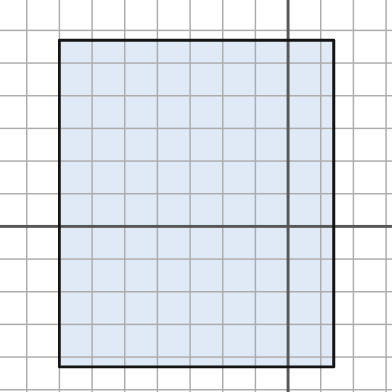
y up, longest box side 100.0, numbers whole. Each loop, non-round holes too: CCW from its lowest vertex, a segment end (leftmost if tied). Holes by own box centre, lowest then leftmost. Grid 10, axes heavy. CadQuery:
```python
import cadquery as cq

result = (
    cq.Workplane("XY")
    .moveTo(-70.0, -43.0)
    .lineTo(14.0, -43.0)
    .lineTo(14.0, 57.0)
    .lineTo(-70.0, 57.0)
    .close()
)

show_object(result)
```